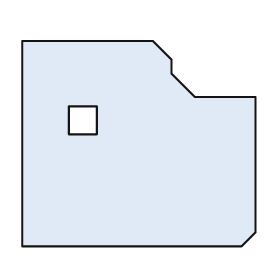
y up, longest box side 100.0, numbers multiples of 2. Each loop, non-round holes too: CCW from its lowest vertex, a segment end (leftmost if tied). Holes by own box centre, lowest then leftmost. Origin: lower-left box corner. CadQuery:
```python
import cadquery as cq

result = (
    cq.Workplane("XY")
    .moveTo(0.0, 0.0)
    .lineTo(94.0, 0.0)
    .lineTo(100.0, 6.0)
    .lineTo(100.0, 64.0)
    .lineTo(74.0, 64.0)
    .lineTo(64.0, 74.0)
    .lineTo(64.0, 80.0)
    .lineTo(56.0, 88.0)
    .lineTo(0.0, 88.0)
    .close()
    .moveTo(20.0, 48.0)
    .lineTo(32.0, 48.0)
    .lineTo(32.0, 60.0)
    .lineTo(20.0, 60.0)
    .close()
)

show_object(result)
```